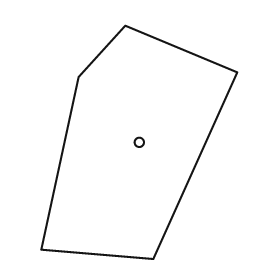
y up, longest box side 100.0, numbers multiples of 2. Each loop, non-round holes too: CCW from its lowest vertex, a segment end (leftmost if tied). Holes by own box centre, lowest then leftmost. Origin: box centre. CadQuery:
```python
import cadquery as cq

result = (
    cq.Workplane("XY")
    .moveTo(6.0, -50.0)
    .lineTo(42.0, 30.0)
    .lineTo(-6.0, 50.0)
    .lineTo(-26.0, 28.0)
    .lineTo(-42.0, -46.0)
    .close()
    .moveTo(0.0, 0.0)
    .circle(2.0)
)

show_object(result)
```